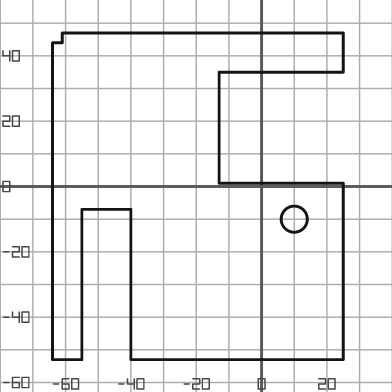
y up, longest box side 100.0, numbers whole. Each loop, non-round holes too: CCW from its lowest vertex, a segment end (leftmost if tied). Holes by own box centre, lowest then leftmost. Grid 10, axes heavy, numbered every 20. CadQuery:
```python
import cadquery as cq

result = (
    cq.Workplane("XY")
    .moveTo(-64.0, -53.0)
    .lineTo(-55.0, -53.0)
    .lineTo(-55.0, -7.0)
    .lineTo(-40.0, -7.0)
    .lineTo(-40.0, -53.0)
    .lineTo(25.0, -53.0)
    .lineTo(25.0, 1.0)
    .lineTo(-13.0, 1.0)
    .lineTo(-13.0, 35.0)
    .lineTo(25.0, 35.0)
    .lineTo(25.0, 47.0)
    .lineTo(-61.0, 47.0)
    .lineTo(-61.0, 44.0)
    .lineTo(-64.0, 44.0)
    .close()
    .moveTo(10.0, -10.0)
    .circle(4.0)
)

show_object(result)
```